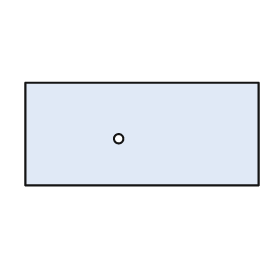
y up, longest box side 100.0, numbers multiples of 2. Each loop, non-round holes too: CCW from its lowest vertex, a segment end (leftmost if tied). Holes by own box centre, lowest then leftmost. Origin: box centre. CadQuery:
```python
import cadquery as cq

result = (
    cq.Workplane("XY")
    .moveTo(-50.0, -22.0)
    .lineTo(50.0, -22.0)
    .lineTo(50.0, 22.0)
    .lineTo(-50.0, 22.0)
    .close()
    .moveTo(-10.0, -2.0)
    .circle(2.0)
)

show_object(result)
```